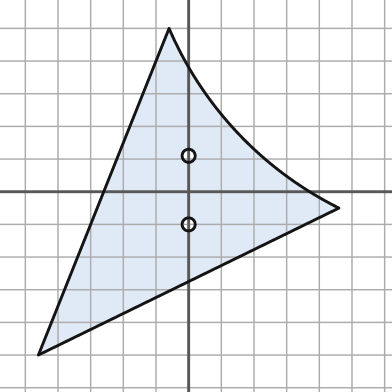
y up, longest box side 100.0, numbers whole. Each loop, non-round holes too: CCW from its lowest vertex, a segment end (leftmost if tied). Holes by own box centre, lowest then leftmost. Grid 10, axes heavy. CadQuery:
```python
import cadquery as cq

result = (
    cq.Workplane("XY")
    .moveTo(-46.0, -50.0)
    .lineTo(46.0, -5.0)
    .threePointArc((15.0, 18.0), (-6.0, 50.0))
    .close()
    .moveTo(0.0, -10.0)
    .circle(2.0)
    .moveTo(0.0, 11.0)
    .circle(2.0)
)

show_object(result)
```